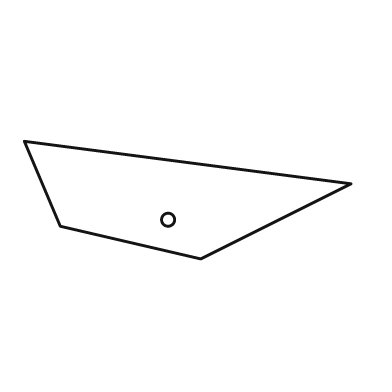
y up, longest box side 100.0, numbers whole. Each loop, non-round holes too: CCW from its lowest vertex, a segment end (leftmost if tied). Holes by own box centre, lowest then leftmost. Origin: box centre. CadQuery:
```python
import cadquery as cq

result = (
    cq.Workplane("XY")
    .moveTo(4.0, -18.0)
    .lineTo(50.0, 5.0)
    .lineTo(-50.0, 18.0)
    .lineTo(-39.0, -8.0)
    .close()
    .moveTo(-6.0, -6.0)
    .circle(2.0)
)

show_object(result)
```